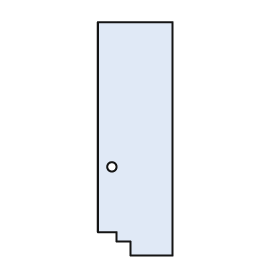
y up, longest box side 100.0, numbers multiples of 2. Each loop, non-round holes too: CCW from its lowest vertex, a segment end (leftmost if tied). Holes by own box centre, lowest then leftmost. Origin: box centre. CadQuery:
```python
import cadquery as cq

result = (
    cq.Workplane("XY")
    .moveTo(-2.0, -50.0)
    .lineTo(16.0, -50.0)
    .lineTo(16.0, 50.0)
    .lineTo(-16.0, 50.0)
    .lineTo(-16.0, -40.0)
    .lineTo(-8.0, -40.0)
    .lineTo(-8.0, -44.0)
    .lineTo(-2.0, -44.0)
    .close()
    .moveTo(-10.0, -12.0)
    .circle(2.0)
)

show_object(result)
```